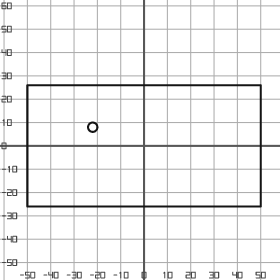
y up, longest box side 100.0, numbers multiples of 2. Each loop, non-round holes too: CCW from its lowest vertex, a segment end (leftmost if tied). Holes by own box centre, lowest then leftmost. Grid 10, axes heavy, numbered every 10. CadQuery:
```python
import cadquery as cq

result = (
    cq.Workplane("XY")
    .moveTo(-50.0, -26.0)
    .lineTo(50.0, -26.0)
    .lineTo(50.0, 26.0)
    .lineTo(-50.0, 26.0)
    .close()
    .moveTo(-22.0, 8.0)
    .circle(2.0)
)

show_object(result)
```